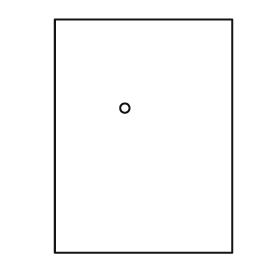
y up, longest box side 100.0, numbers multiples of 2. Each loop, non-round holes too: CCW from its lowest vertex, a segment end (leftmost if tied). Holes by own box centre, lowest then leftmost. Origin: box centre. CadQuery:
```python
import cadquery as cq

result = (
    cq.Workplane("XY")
    .moveTo(-38.0, -50.0)
    .lineTo(38.0, -50.0)
    .lineTo(38.0, 50.0)
    .lineTo(-38.0, 50.0)
    .close()
    .moveTo(-8.0, 12.0)
    .circle(2.0)
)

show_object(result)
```